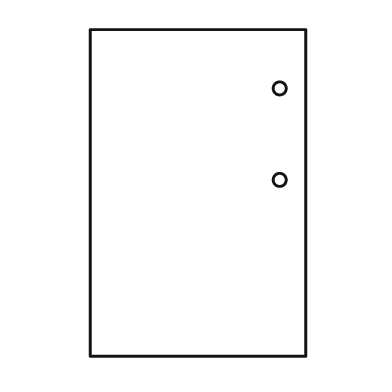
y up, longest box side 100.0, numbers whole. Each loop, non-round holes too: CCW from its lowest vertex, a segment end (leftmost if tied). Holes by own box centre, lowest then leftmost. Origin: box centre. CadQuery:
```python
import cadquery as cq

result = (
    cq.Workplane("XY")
    .moveTo(-33.0, -50.0)
    .lineTo(33.0, -50.0)
    .lineTo(33.0, 50.0)
    .lineTo(-33.0, 50.0)
    .close()
    .moveTo(25.0, 4.0)
    .circle(2.0)
    .moveTo(25.0, 32.0)
    .circle(2.0)
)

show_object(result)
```